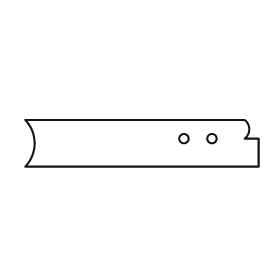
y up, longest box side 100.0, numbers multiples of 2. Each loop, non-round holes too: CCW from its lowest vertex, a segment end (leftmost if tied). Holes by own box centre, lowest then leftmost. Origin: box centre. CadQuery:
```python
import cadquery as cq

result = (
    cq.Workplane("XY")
    .moveTo(-50.0, -10.0)
    .lineTo(50.0, -10.0)
    .lineTo(50.0, 2.0)
    .lineTo(44.0, 2.0)
    .threePointArc((46.0, 6.0), (44.0, 10.0))
    .lineTo(-50.0, 10.0)
    .threePointArc((-46.0, 0.0), (-50.0, -10.0))
    .close()
    .moveTo(18.0, 2.0)
    .circle(2.0)
    .moveTo(30.0, 2.0)
    .circle(2.0)
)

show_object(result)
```